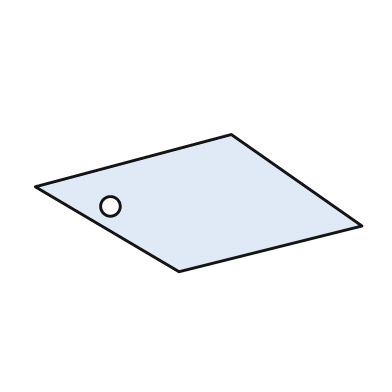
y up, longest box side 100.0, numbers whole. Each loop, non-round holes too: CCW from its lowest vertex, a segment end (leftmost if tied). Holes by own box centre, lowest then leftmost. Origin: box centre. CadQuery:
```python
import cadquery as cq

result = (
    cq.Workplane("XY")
    .moveTo(-6.0, -21.0)
    .lineTo(50.0, -7.0)
    .lineTo(10.0, 21.0)
    .lineTo(-50.0, 5.0)
    .close()
    .moveTo(-27.0, -1.0)
    .circle(3.0)
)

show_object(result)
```